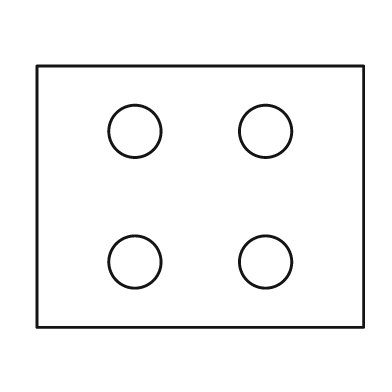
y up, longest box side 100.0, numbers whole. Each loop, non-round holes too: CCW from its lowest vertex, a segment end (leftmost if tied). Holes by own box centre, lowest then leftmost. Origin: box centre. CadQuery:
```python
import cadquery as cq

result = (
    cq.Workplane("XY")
    .moveTo(-50.0, -40.0)
    .lineTo(50.0, -40.0)
    .lineTo(50.0, 40.0)
    .lineTo(-50.0, 40.0)
    .close()
    .moveTo(-20.0, -20.0)
    .circle(8.0)
    .moveTo(20.0, -20.0)
    .circle(8.0)
    .moveTo(-20.0, 20.0)
    .circle(8.0)
    .moveTo(20.0, 20.0)
    .circle(8.0)
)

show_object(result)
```